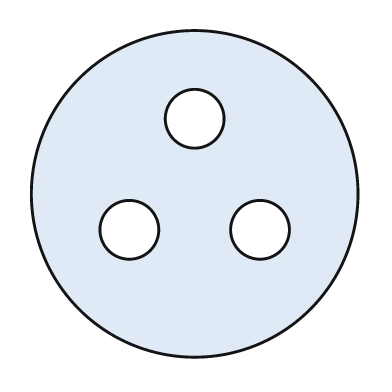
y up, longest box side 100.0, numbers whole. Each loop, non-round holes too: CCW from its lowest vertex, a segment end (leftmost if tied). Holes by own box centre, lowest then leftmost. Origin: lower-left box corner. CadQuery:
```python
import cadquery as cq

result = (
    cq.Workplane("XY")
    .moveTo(50.0, 50.0)
    .circle(50.0)
    .moveTo(30.0, 39.0)
    .circle(9.0)
    .moveTo(70.0, 39.0)
    .circle(9.0)
    .moveTo(50.0, 73.0)
    .circle(9.0)
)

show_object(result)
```